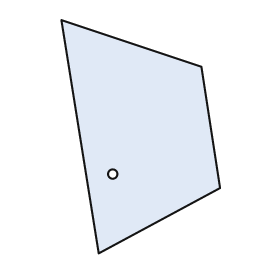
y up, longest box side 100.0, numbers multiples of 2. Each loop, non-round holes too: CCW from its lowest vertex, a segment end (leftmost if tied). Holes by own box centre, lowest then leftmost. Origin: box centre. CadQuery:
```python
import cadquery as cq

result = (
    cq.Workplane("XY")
    .moveTo(-18.0, -50.0)
    .lineTo(34.0, -22.0)
    .lineTo(26.0, 30.0)
    .lineTo(-34.0, 50.0)
    .close()
    .moveTo(-12.0, -16.0)
    .circle(2.0)
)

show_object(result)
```